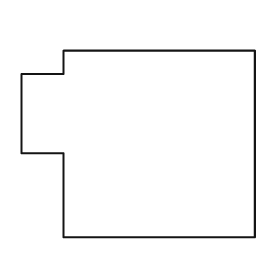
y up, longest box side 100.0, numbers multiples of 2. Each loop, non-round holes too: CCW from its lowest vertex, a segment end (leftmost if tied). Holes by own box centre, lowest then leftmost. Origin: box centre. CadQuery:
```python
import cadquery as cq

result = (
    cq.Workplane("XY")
    .moveTo(-32.0, -40.0)
    .lineTo(50.0, -40.0)
    .lineTo(50.0, 40.0)
    .lineTo(-32.0, 40.0)
    .lineTo(-32.0, 30.0)
    .lineTo(-50.0, 30.0)
    .lineTo(-50.0, -4.0)
    .lineTo(-32.0, -4.0)
    .close()
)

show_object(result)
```